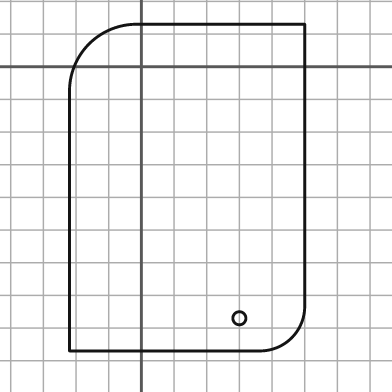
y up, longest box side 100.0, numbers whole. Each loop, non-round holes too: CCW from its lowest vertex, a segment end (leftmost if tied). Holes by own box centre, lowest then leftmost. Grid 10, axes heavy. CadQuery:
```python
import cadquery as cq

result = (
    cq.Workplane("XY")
    .moveTo(-22.0, -87.0)
    .lineTo(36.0, -87.0)
    .threePointArc((46.0, -83.0), (50.0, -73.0))
    .lineTo(50.0, 13.0)
    .lineTo(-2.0, 13.0)
    .threePointArc((-16.0, 7.0), (-22.0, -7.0))
    .close()
    .moveTo(30.0, -77.0)
    .circle(2.0)
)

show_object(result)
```